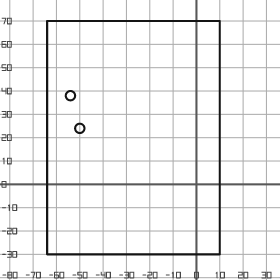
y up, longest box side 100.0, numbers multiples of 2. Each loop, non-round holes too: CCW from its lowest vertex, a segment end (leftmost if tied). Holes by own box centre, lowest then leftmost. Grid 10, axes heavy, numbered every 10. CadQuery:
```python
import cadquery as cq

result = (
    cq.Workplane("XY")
    .moveTo(-64.0, -30.0)
    .lineTo(10.0, -30.0)
    .lineTo(10.0, 70.0)
    .lineTo(-64.0, 70.0)
    .close()
    .moveTo(-50.0, 24.0)
    .circle(2.0)
    .moveTo(-54.0, 38.0)
    .circle(2.0)
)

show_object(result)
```